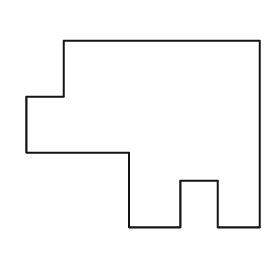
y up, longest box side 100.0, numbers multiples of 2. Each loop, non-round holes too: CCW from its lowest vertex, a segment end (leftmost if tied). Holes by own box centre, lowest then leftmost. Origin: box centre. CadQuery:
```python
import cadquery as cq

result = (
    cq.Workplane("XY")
    .moveTo(-6.0, -40.0)
    .lineTo(16.0, -40.0)
    .lineTo(16.0, -20.0)
    .lineTo(32.0, -20.0)
    .lineTo(32.0, -40.0)
    .lineTo(50.0, -40.0)
    .lineTo(50.0, 40.0)
    .lineTo(-34.0, 40.0)
    .lineTo(-34.0, 16.0)
    .lineTo(-50.0, 16.0)
    .lineTo(-50.0, -8.0)
    .lineTo(-6.0, -8.0)
    .close()
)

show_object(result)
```